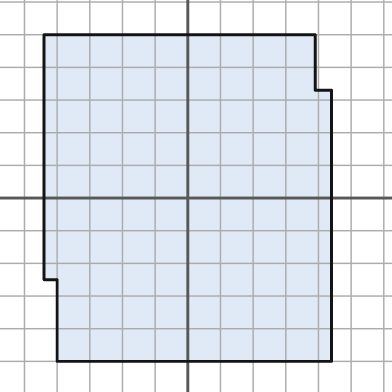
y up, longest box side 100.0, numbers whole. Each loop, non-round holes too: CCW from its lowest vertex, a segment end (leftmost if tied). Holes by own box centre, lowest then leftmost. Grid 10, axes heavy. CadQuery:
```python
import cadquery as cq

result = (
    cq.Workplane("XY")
    .moveTo(-40.0, -50.0)
    .lineTo(44.0, -50.0)
    .lineTo(44.0, 33.0)
    .lineTo(39.0, 33.0)
    .lineTo(39.0, 50.0)
    .lineTo(-44.0, 50.0)
    .lineTo(-44.0, -25.0)
    .lineTo(-40.0, -25.0)
    .close()
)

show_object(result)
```